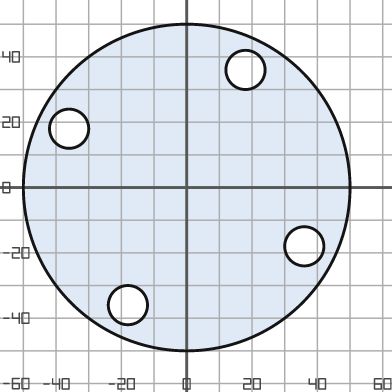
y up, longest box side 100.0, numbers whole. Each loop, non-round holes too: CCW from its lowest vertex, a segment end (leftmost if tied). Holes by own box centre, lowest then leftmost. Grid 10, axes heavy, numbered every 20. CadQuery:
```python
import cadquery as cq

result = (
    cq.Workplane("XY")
    .moveTo(0.0, 0.0)
    .circle(50.0)
    .moveTo(-18.0, -36.0)
    .circle(6.0)
    .moveTo(36.0, -18.0)
    .circle(6.0)
    .moveTo(-36.0, 18.0)
    .circle(6.0)
    .moveTo(18.0, 36.0)
    .circle(6.0)
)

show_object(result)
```